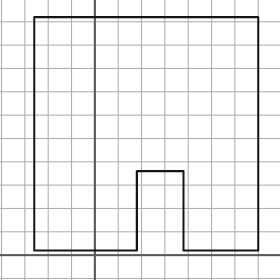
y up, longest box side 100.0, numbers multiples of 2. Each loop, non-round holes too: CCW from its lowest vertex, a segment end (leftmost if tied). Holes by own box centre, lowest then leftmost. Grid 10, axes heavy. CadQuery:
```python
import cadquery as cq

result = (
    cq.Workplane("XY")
    .moveTo(-26.0, 2.0)
    .lineTo(18.0, 2.0)
    .lineTo(18.0, 36.0)
    .lineTo(38.0, 36.0)
    .lineTo(38.0, 2.0)
    .lineTo(70.0, 2.0)
    .lineTo(70.0, 102.0)
    .lineTo(-26.0, 102.0)
    .close()
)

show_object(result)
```